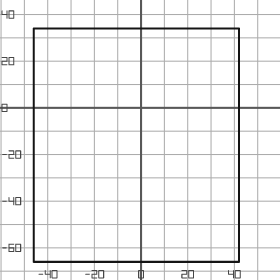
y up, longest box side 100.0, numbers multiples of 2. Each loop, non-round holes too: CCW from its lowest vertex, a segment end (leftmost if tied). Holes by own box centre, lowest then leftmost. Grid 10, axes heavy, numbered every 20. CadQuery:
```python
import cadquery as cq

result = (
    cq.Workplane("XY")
    .moveTo(-46.0, -66.0)
    .lineTo(42.0, -66.0)
    .lineTo(42.0, 34.0)
    .lineTo(-46.0, 34.0)
    .close()
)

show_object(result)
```